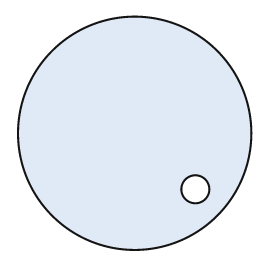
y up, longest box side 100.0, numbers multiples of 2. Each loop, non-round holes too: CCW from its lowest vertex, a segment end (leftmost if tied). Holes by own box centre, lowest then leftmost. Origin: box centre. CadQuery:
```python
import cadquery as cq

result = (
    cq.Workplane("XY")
    .moveTo(0.0, 0.0)
    .circle(50.0)
    .moveTo(26.0, -24.0)
    .circle(6.0)
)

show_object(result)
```